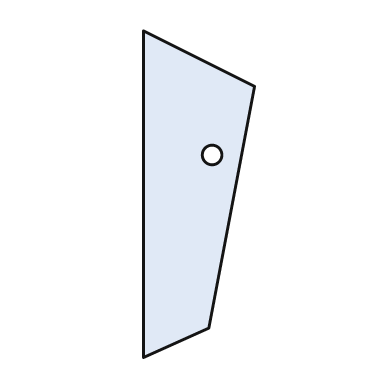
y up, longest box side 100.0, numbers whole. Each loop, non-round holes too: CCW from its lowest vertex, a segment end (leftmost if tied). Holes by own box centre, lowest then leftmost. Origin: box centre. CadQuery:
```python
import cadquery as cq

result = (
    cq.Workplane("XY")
    .moveTo(-17.0, -50.0)
    .lineTo(3.0, -41.0)
    .lineTo(17.0, 33.0)
    .lineTo(-17.0, 50.0)
    .close()
    .moveTo(4.0, 12.0)
    .circle(3.0)
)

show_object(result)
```